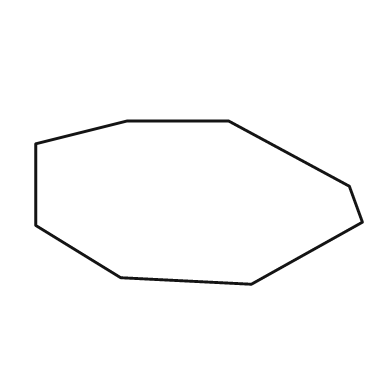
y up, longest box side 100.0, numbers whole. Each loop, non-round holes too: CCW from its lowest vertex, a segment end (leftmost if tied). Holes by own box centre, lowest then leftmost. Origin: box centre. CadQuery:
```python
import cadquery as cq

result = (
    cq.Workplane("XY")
    .moveTo(16.0, -25.0)
    .lineTo(50.0, -6.0)
    .lineTo(46.0, 5.0)
    .lineTo(9.0, 25.0)
    .lineTo(-22.0, 25.0)
    .lineTo(-50.0, 18.0)
    .lineTo(-50.0, -7.0)
    .lineTo(-24.0, -23.0)
    .close()
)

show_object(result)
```